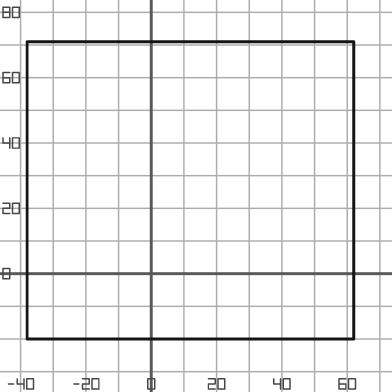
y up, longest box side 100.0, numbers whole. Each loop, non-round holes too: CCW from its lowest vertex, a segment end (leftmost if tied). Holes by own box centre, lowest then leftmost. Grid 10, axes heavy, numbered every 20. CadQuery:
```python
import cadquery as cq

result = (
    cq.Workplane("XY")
    .moveTo(-38.0, -20.0)
    .lineTo(62.0, -20.0)
    .lineTo(62.0, 71.0)
    .lineTo(-38.0, 71.0)
    .close()
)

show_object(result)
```